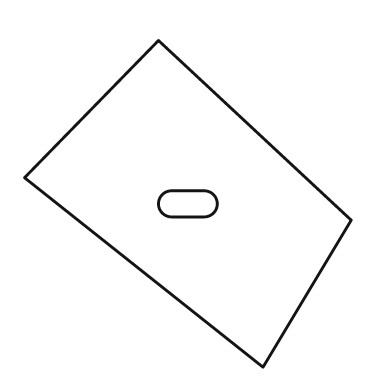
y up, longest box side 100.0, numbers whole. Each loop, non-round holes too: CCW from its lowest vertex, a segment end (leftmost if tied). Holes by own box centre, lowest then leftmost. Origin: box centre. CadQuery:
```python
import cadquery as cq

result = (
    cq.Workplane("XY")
    .moveTo(23.0, -50.0)
    .lineTo(50.0, -5.0)
    .lineTo(-9.0, 50.0)
    .lineTo(-50.0, 8.0)
    .close()
    .moveTo(-5.0, -4.0)
    .lineTo(5.0, -4.0)
    .threePointArc((9.0, 0.0), (5.0, 4.0))
    .lineTo(-5.0, 4.0)
    .threePointArc((-9.0, 0.0), (-5.0, -4.0))
    .close()
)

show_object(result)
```